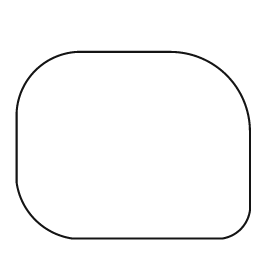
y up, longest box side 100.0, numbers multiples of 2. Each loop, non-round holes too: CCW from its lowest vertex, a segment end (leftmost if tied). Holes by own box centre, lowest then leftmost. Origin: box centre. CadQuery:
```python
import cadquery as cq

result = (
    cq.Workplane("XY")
    .moveTo(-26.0, -40.0)
    .lineTo(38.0, -40.0)
    .threePointArc((46.0, -36.0), (50.0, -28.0))
    .lineTo(50.0, 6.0)
    .threePointArc((40.0, 30.0), (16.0, 40.0))
    .lineTo(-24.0, 40.0)
    .threePointArc((-42.0, 32.0), (-50.0, 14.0))
    .lineTo(-50.0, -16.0)
    .threePointArc((-42.0, -32.0), (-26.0, -40.0))
    .close()
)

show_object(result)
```